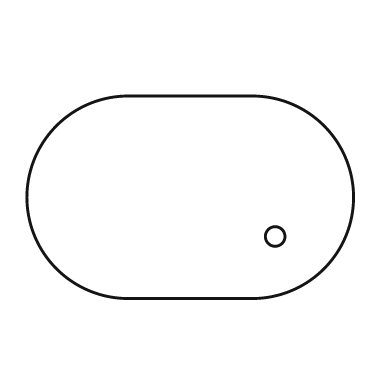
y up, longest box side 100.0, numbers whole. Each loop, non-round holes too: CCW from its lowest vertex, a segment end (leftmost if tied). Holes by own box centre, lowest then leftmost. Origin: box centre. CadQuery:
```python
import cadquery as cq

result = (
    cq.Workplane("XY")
    .moveTo(-19.0, -31.0)
    .lineTo(19.0, -31.0)
    .threePointArc((50.0, 0.0), (19.0, 31.0))
    .lineTo(-19.0, 31.0)
    .threePointArc((-50.0, 0.0), (-19.0, -31.0))
    .close()
    .moveTo(26.0, -12.0)
    .circle(3.0)
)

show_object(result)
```